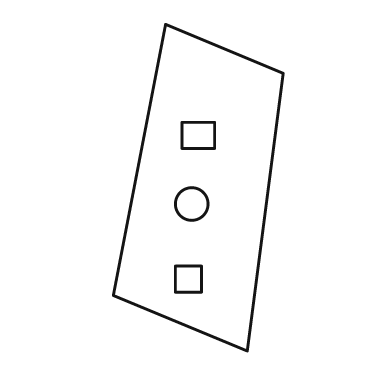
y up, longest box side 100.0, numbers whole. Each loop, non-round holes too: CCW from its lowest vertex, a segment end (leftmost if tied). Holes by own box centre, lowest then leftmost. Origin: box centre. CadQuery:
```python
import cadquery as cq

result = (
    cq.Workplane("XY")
    .moveTo(15.0, -50.0)
    .lineTo(26.0, 35.0)
    .lineTo(-10.0, 50.0)
    .lineTo(-26.0, -33.0)
    .close()
    .moveTo(-7.0, -32.0)
    .lineTo(1.0, -32.0)
    .lineTo(1.0, -24.0)
    .lineTo(-7.0, -24.0)
    .close()
    .moveTo(-2.0, -5.0)
    .circle(5.0)
    .moveTo(-5.0, 12.0)
    .lineTo(5.0, 12.0)
    .lineTo(5.0, 20.0)
    .lineTo(-5.0, 20.0)
    .close()
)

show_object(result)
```